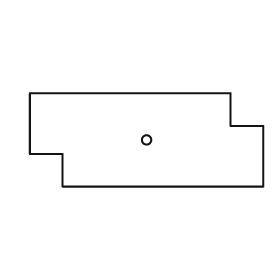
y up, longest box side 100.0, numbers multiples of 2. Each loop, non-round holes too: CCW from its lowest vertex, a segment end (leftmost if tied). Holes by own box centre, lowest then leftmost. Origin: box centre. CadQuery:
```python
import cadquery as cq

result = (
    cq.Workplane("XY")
    .moveTo(-36.0, -20.0)
    .lineTo(50.0, -20.0)
    .lineTo(50.0, 6.0)
    .lineTo(36.0, 6.0)
    .lineTo(36.0, 20.0)
    .lineTo(-50.0, 20.0)
    .lineTo(-50.0, -6.0)
    .lineTo(-36.0, -6.0)
    .close()
    .moveTo(0.0, 0.0)
    .circle(2.0)
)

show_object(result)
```